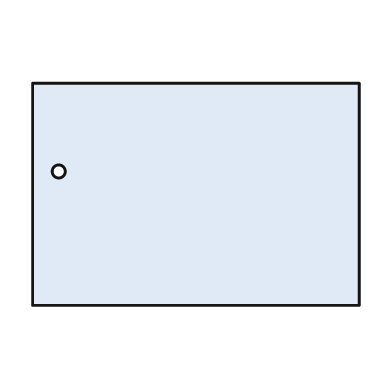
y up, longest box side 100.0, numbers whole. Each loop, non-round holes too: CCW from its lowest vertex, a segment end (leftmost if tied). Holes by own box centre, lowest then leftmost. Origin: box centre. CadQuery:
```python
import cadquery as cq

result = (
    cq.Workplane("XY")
    .moveTo(-50.0, -34.0)
    .lineTo(50.0, -34.0)
    .lineTo(50.0, 34.0)
    .lineTo(-50.0, 34.0)
    .close()
    .moveTo(-42.0, 7.0)
    .circle(2.0)
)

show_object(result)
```